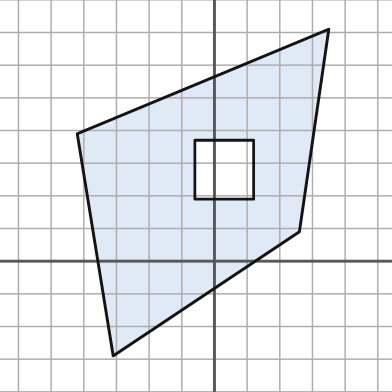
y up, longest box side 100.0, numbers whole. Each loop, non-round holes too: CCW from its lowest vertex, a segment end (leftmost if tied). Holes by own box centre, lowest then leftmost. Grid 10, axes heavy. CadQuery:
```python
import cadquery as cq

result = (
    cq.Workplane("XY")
    .moveTo(-31.0, -29.0)
    .lineTo(26.0, 9.0)
    .lineTo(35.0, 71.0)
    .lineTo(-42.0, 39.0)
    .close()
    .moveTo(-6.0, 19.0)
    .lineTo(12.0, 19.0)
    .lineTo(12.0, 37.0)
    .lineTo(-6.0, 37.0)
    .close()
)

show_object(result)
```